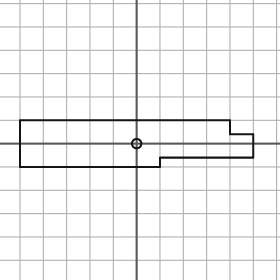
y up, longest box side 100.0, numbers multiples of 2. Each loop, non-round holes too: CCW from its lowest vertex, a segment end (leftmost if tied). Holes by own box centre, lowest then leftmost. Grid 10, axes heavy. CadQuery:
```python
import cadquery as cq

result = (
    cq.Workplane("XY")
    .moveTo(-50.0, -10.0)
    .lineTo(10.0, -10.0)
    .lineTo(10.0, -6.0)
    .lineTo(50.0, -6.0)
    .lineTo(50.0, 4.0)
    .lineTo(40.0, 4.0)
    .lineTo(40.0, 10.0)
    .lineTo(-50.0, 10.0)
    .close()
    .moveTo(0.0, 0.0)
    .circle(2.0)
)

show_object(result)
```